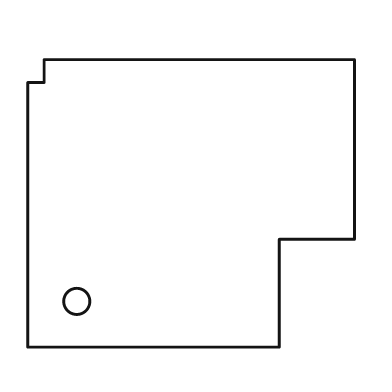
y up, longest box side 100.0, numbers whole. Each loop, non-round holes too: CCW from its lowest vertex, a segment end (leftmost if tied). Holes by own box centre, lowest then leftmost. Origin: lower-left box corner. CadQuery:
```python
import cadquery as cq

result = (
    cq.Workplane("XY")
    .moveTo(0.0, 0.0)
    .lineTo(77.0, 0.0)
    .lineTo(77.0, 33.0)
    .lineTo(100.0, 33.0)
    .lineTo(100.0, 88.0)
    .lineTo(5.0, 88.0)
    .lineTo(5.0, 81.0)
    .lineTo(0.0, 81.0)
    .close()
    .moveTo(15.0, 14.0)
    .circle(4.0)
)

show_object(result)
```